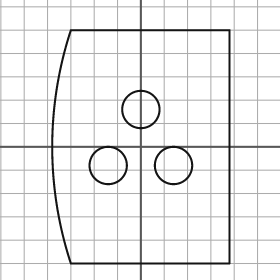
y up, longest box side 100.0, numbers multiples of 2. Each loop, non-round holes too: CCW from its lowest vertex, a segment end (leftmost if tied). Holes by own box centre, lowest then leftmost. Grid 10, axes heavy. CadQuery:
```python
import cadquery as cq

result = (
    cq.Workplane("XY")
    .moveTo(-30.0, -50.0)
    .lineTo(38.0, -50.0)
    .lineTo(38.0, 50.0)
    .lineTo(-30.0, 50.0)
    .threePointArc((-38.0, 0.0), (-30.0, -50.0))
    .close()
    .moveTo(-14.0, -8.0)
    .circle(8.0)
    .moveTo(14.0, -8.0)
    .circle(8.0)
    .moveTo(0.0, 16.0)
    .circle(8.0)
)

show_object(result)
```